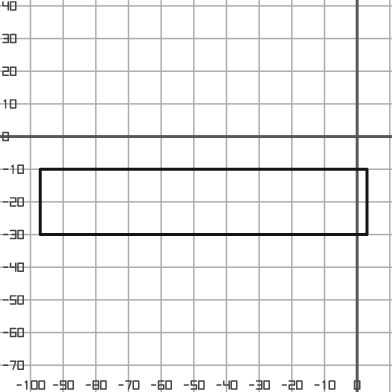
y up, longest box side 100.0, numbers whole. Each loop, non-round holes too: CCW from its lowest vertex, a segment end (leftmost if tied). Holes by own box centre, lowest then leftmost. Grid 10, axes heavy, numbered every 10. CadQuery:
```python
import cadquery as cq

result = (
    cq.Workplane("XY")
    .moveTo(-97.0, -30.0)
    .lineTo(3.0, -30.0)
    .lineTo(3.0, -10.0)
    .lineTo(-97.0, -10.0)
    .close()
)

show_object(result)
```